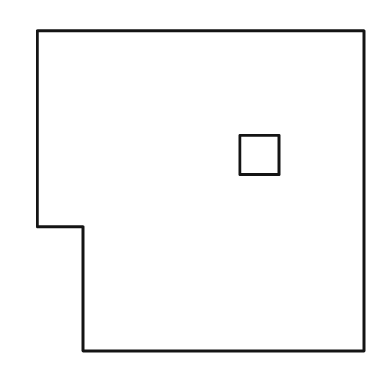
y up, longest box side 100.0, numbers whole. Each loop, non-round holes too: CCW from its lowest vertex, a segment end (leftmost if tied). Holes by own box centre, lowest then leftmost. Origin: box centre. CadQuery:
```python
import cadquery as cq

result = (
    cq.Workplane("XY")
    .moveTo(-36.0, -49.0)
    .lineTo(50.0, -49.0)
    .lineTo(50.0, 49.0)
    .lineTo(-50.0, 49.0)
    .lineTo(-50.0, -11.0)
    .lineTo(-36.0, -11.0)
    .close()
    .moveTo(12.0, 5.0)
    .lineTo(24.0, 5.0)
    .lineTo(24.0, 17.0)
    .lineTo(12.0, 17.0)
    .close()
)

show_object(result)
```